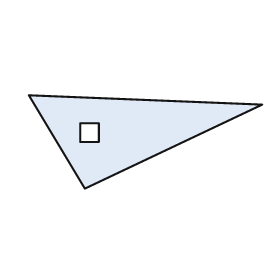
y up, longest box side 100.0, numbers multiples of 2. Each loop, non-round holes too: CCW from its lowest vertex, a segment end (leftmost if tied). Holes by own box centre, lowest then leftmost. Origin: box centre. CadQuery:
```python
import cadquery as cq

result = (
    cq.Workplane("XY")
    .moveTo(-26.0, -20.0)
    .lineTo(50.0, 16.0)
    .lineTo(-50.0, 20.0)
    .close()
    .moveTo(-28.0, 0.0)
    .lineTo(-20.0, 0.0)
    .lineTo(-20.0, 8.0)
    .lineTo(-28.0, 8.0)
    .close()
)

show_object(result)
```